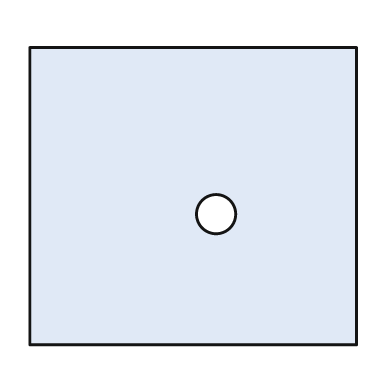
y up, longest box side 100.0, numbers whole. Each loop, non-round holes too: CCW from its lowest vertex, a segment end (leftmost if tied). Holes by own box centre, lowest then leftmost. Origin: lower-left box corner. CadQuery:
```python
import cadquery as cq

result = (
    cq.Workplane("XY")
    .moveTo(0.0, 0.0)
    .lineTo(100.0, 0.0)
    .lineTo(100.0, 91.0)
    .lineTo(0.0, 91.0)
    .close()
    .moveTo(57.0, 40.0)
    .circle(6.0)
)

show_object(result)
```